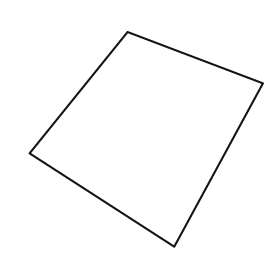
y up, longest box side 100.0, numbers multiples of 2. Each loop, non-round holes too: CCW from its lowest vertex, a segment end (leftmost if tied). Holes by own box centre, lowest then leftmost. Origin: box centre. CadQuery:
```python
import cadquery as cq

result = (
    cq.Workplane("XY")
    .moveTo(12.0, -46.0)
    .lineTo(50.0, 24.0)
    .lineTo(-8.0, 46.0)
    .lineTo(-50.0, -6.0)
    .close()
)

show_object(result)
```